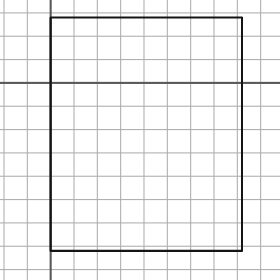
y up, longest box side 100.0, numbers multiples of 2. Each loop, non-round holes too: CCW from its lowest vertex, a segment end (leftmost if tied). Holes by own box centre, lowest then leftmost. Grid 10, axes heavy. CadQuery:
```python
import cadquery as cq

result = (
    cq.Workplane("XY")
    .moveTo(0.0, -72.0)
    .lineTo(82.0, -72.0)
    .lineTo(82.0, 28.0)
    .lineTo(0.0, 28.0)
    .close()
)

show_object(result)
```